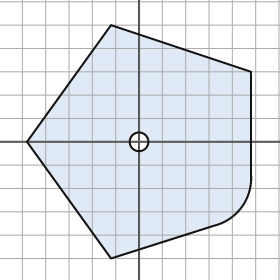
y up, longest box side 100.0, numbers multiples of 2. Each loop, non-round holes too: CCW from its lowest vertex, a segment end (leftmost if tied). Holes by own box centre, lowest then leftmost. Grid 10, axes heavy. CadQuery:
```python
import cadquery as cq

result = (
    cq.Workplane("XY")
    .moveTo(-12.0, -50.0)
    .lineTo(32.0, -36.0)
    .threePointArc((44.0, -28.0), (48.0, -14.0))
    .lineTo(48.0, 30.0)
    .lineTo(-12.0, 50.0)
    .lineTo(-48.0, 0.0)
    .close()
    .moveTo(0.0, 0.0)
    .circle(4.0)
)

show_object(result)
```